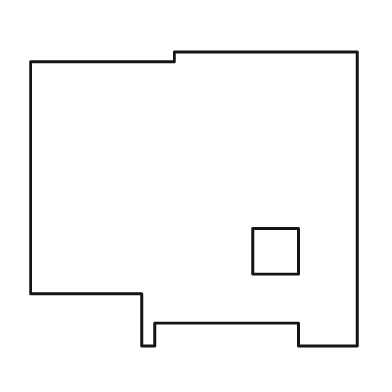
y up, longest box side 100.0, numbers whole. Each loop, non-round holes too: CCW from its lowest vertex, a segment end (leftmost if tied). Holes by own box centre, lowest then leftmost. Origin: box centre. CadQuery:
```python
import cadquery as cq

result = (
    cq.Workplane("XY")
    .moveTo(-16.0, -45.0)
    .lineTo(-12.0, -45.0)
    .lineTo(-12.0, -38.0)
    .lineTo(32.0, -38.0)
    .lineTo(32.0, -45.0)
    .lineTo(50.0, -45.0)
    .lineTo(50.0, 45.0)
    .lineTo(-6.0, 45.0)
    .lineTo(-6.0, 42.0)
    .lineTo(-50.0, 42.0)
    .lineTo(-50.0, -29.0)
    .lineTo(-16.0, -29.0)
    .close()
    .moveTo(18.0, -23.0)
    .lineTo(32.0, -23.0)
    .lineTo(32.0, -9.0)
    .lineTo(18.0, -9.0)
    .close()
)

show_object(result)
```